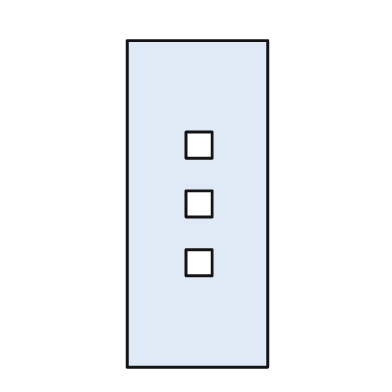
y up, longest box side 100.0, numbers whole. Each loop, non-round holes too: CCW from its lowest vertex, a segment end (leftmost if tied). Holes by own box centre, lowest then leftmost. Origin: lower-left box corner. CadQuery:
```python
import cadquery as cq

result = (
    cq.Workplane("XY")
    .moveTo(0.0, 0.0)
    .lineTo(43.0, 0.0)
    .lineTo(43.0, 100.0)
    .lineTo(0.0, 100.0)
    .close()
    .moveTo(18.0, 28.0)
    .lineTo(26.0, 28.0)
    .lineTo(26.0, 36.0)
    .lineTo(18.0, 36.0)
    .close()
    .moveTo(18.0, 46.0)
    .lineTo(26.0, 46.0)
    .lineTo(26.0, 54.0)
    .lineTo(18.0, 54.0)
    .close()
    .moveTo(18.0, 64.0)
    .lineTo(26.0, 64.0)
    .lineTo(26.0, 72.0)
    .lineTo(18.0, 72.0)
    .close()
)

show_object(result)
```